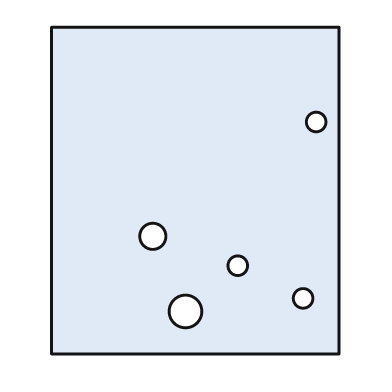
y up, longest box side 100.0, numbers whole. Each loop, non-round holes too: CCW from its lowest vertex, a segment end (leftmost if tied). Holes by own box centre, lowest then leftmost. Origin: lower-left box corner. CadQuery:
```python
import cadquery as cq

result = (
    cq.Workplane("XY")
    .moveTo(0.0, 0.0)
    .lineTo(88.0, 0.0)
    .lineTo(88.0, 100.0)
    .lineTo(0.0, 100.0)
    .close()
    .moveTo(41.0, 13.0)
    .circle(5.0)
    .moveTo(77.0, 17.0)
    .circle(3.0)
    .moveTo(57.0, 27.0)
    .circle(3.0)
    .moveTo(31.0, 36.0)
    .circle(4.0)
    .moveTo(81.0, 71.0)
    .circle(3.0)
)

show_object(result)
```